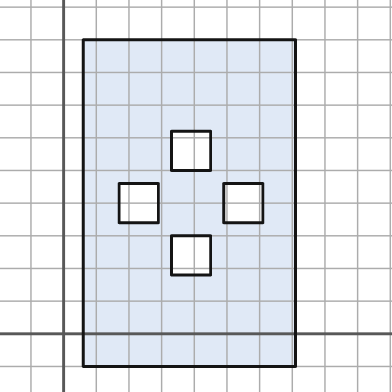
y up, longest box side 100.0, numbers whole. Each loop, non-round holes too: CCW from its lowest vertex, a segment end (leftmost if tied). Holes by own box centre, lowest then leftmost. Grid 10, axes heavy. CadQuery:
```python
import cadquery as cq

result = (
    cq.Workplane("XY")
    .moveTo(6.0, -10.0)
    .lineTo(71.0, -10.0)
    .lineTo(71.0, 90.0)
    .lineTo(6.0, 90.0)
    .close()
    .moveTo(33.0, 18.0)
    .lineTo(45.0, 18.0)
    .lineTo(45.0, 30.0)
    .lineTo(33.0, 30.0)
    .close()
    .moveTo(17.0, 34.0)
    .lineTo(29.0, 34.0)
    .lineTo(29.0, 46.0)
    .lineTo(17.0, 46.0)
    .close()
    .moveTo(49.0, 34.0)
    .lineTo(61.0, 34.0)
    .lineTo(61.0, 46.0)
    .lineTo(49.0, 46.0)
    .close()
    .moveTo(33.0, 50.0)
    .lineTo(45.0, 50.0)
    .lineTo(45.0, 62.0)
    .lineTo(33.0, 62.0)
    .close()
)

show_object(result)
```